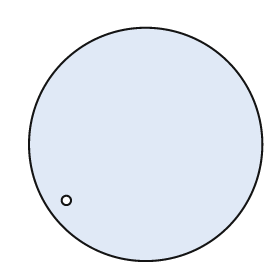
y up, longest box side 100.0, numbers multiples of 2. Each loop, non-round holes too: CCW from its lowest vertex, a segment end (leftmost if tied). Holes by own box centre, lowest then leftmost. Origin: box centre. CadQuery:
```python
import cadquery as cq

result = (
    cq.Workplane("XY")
    .moveTo(0.0, 0.0)
    .circle(50.0)
    .moveTo(-34.0, -24.0)
    .circle(2.0)
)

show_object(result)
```